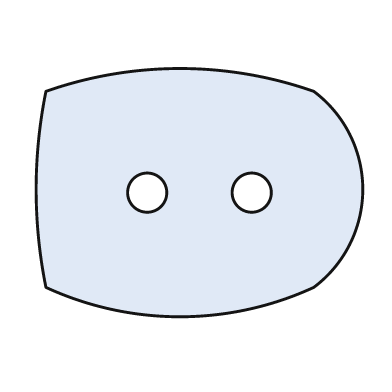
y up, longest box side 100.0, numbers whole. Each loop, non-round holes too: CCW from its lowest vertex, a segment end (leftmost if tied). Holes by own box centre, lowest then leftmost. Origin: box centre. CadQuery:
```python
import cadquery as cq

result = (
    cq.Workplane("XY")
    .moveTo(-47.0, -29.0)
    .threePointArc((-6.0, -38.0), (35.0, -29.0))
    .threePointArc((50.0, 1.0), (35.0, 31.0))
    .threePointArc((-6.0, 38.0), (-47.0, 31.0))
    .threePointArc((-50.0, 1.0), (-47.0, -29.0))
    .close()
    .moveTo(-16.0, 0.0)
    .circle(6.0)
    .moveTo(16.0, 0.0)
    .circle(6.0)
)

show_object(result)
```